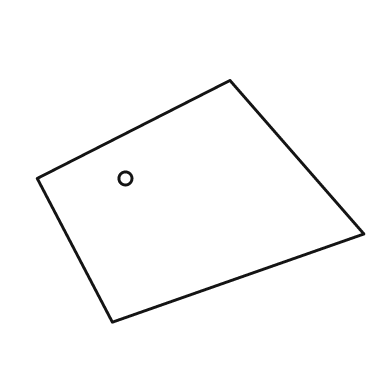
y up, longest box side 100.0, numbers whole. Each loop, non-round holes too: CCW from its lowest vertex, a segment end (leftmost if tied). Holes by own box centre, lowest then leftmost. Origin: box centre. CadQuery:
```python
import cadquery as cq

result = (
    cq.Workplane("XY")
    .moveTo(-27.0, -37.0)
    .lineTo(50.0, -10.0)
    .lineTo(9.0, 37.0)
    .lineTo(-50.0, 7.0)
    .close()
    .moveTo(-23.0, 7.0)
    .circle(2.0)
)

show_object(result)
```